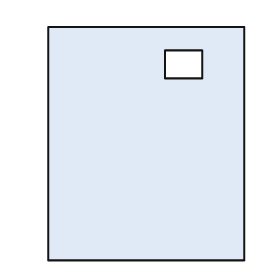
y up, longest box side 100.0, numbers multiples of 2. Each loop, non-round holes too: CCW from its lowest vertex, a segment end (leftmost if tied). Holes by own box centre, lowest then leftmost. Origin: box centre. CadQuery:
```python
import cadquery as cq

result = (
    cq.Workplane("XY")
    .moveTo(-42.0, -50.0)
    .lineTo(42.0, -50.0)
    .lineTo(42.0, 50.0)
    .lineTo(-42.0, 50.0)
    .close()
    .moveTo(8.0, 28.0)
    .lineTo(24.0, 28.0)
    .lineTo(24.0, 40.0)
    .lineTo(8.0, 40.0)
    .close()
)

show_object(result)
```